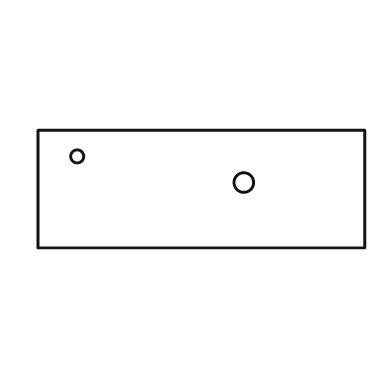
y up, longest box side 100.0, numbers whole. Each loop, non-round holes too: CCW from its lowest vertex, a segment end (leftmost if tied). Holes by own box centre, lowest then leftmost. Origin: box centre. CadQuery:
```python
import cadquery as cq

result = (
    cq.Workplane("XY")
    .moveTo(-50.0, -18.0)
    .lineTo(50.0, -18.0)
    .lineTo(50.0, 18.0)
    .lineTo(-50.0, 18.0)
    .close()
    .moveTo(13.0, 2.0)
    .circle(3.0)
    .moveTo(-38.0, 10.0)
    .circle(2.0)
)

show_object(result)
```